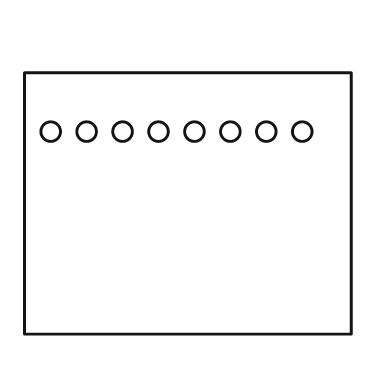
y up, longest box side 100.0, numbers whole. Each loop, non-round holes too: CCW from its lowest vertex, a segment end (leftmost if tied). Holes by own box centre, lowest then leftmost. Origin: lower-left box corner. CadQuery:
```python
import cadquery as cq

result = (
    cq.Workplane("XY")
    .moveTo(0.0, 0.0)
    .lineTo(100.0, 0.0)
    .lineTo(100.0, 80.0)
    .lineTo(0.0, 80.0)
    .close()
    .moveTo(8.0, 62.0)
    .circle(3.0)
    .moveTo(19.0, 62.0)
    .circle(3.0)
    .moveTo(30.0, 62.0)
    .circle(3.0)
    .moveTo(41.0, 62.0)
    .circle(3.0)
    .moveTo(52.0, 62.0)
    .circle(3.0)
    .moveTo(63.0, 62.0)
    .circle(3.0)
    .moveTo(74.0, 62.0)
    .circle(3.0)
    .moveTo(85.0, 62.0)
    .circle(3.0)
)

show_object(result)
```